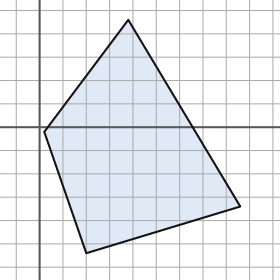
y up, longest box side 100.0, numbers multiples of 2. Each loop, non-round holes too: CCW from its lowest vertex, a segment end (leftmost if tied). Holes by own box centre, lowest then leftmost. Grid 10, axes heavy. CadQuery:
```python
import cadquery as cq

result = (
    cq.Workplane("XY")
    .moveTo(20.0, -54.0)
    .lineTo(86.0, -34.0)
    .lineTo(38.0, 46.0)
    .lineTo(2.0, -2.0)
    .close()
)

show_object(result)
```